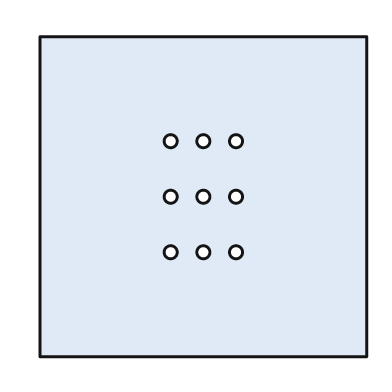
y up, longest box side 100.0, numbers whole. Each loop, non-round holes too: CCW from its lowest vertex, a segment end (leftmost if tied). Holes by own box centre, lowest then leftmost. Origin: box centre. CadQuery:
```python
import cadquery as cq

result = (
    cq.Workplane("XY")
    .moveTo(-50.0, -49.0)
    .lineTo(50.0, -49.0)
    .lineTo(50.0, 49.0)
    .lineTo(-50.0, 49.0)
    .close()
    .moveTo(-10.0, -17.0)
    .circle(2.0)
    .moveTo(0.0, -17.0)
    .circle(2.0)
    .moveTo(10.0, -17.0)
    .circle(2.0)
    .moveTo(-10.0, 0.0)
    .circle(2.0)
    .moveTo(0.0, 0.0)
    .circle(2.0)
    .moveTo(10.0, 0.0)
    .circle(2.0)
    .moveTo(-10.0, 17.0)
    .circle(2.0)
    .moveTo(0.0, 17.0)
    .circle(2.0)
    .moveTo(10.0, 17.0)
    .circle(2.0)
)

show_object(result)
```